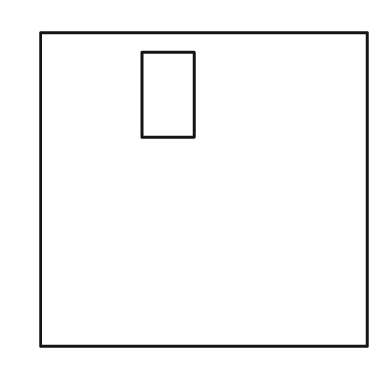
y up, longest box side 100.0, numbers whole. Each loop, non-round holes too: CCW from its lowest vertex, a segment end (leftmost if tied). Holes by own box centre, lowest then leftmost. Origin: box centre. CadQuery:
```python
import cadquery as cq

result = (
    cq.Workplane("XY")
    .moveTo(-50.0, -48.0)
    .lineTo(50.0, -48.0)
    .lineTo(50.0, 48.0)
    .lineTo(-50.0, 48.0)
    .close()
    .moveTo(-19.0, 16.0)
    .lineTo(-3.0, 16.0)
    .lineTo(-3.0, 42.0)
    .lineTo(-19.0, 42.0)
    .close()
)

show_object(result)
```